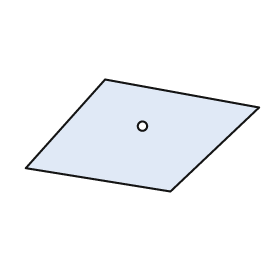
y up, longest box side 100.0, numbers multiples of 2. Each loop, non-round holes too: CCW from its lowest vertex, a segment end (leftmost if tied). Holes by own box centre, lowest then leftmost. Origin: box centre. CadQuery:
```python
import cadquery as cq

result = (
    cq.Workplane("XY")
    .moveTo(12.0, -24.0)
    .lineTo(50.0, 12.0)
    .lineTo(-16.0, 24.0)
    .lineTo(-50.0, -14.0)
    .close()
    .moveTo(0.0, 4.0)
    .circle(2.0)
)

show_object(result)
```